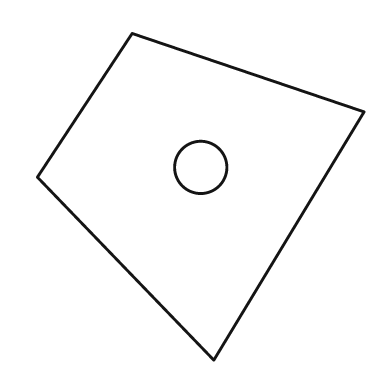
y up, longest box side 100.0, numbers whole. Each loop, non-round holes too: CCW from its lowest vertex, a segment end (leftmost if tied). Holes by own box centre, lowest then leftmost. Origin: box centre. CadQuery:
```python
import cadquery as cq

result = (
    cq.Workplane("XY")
    .moveTo(4.0, -50.0)
    .lineTo(50.0, 26.0)
    .lineTo(-21.0, 50.0)
    .lineTo(-50.0, 6.0)
    .close()
    .moveTo(0.0, 9.0)
    .circle(8.0)
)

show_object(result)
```